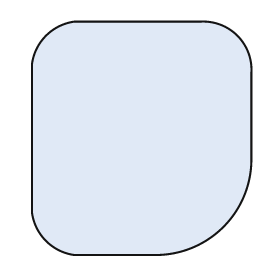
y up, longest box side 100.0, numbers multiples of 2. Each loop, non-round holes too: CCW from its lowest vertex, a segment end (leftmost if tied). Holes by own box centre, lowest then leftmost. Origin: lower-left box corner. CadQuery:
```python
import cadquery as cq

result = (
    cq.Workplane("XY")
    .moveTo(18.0, 0.0)
    .lineTo(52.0, 0.0)
    .threePointArc((82.0, 12.0), (94.0, 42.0))
    .lineTo(94.0, 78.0)
    .threePointArc((88.0, 94.0), (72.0, 100.0))
    .lineTo(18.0, 100.0)
    .threePointArc((6.0, 94.0), (0.0, 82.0))
    .lineTo(0.0, 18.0)
    .threePointArc((6.0, 6.0), (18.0, 0.0))
    .close()
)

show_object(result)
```